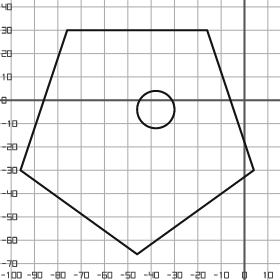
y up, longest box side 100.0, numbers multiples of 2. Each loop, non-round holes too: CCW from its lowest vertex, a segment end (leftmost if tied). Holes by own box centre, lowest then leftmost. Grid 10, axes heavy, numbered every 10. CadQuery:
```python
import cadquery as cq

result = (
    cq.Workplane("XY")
    .moveTo(-46.0, -66.0)
    .lineTo(4.0, -30.0)
    .lineTo(-16.0, 30.0)
    .lineTo(-76.0, 30.0)
    .lineTo(-96.0, -30.0)
    .close()
    .moveTo(-38.0, -4.0)
    .circle(8.0)
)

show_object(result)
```